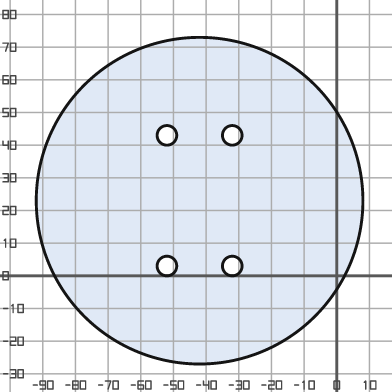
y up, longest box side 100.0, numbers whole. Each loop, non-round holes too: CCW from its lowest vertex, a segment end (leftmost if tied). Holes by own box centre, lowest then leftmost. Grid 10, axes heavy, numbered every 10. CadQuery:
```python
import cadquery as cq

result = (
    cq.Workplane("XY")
    .moveTo(-42.0, 23.0)
    .circle(50.0)
    .moveTo(-52.0, 3.0)
    .circle(3.0)
    .moveTo(-32.0, 3.0)
    .circle(3.0)
    .moveTo(-52.0, 43.0)
    .circle(3.0)
    .moveTo(-32.0, 43.0)
    .circle(3.0)
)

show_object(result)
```